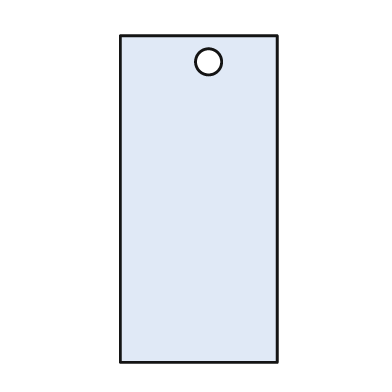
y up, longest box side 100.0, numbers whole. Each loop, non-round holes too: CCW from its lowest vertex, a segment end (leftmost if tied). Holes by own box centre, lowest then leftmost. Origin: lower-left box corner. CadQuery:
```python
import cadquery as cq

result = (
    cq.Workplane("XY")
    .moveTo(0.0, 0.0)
    .lineTo(48.0, 0.0)
    .lineTo(48.0, 100.0)
    .lineTo(0.0, 100.0)
    .close()
    .moveTo(27.0, 92.0)
    .circle(4.0)
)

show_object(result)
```